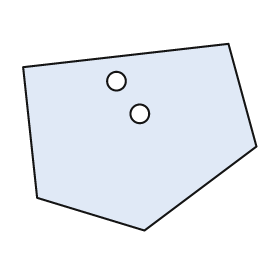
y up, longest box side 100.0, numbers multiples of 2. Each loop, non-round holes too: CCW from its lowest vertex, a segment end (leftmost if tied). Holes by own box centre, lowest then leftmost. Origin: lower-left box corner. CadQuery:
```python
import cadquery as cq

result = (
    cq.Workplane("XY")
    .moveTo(52.0, 0.0)
    .lineTo(100.0, 36.0)
    .lineTo(88.0, 80.0)
    .lineTo(0.0, 70.0)
    .lineTo(6.0, 14.0)
    .close()
    .moveTo(50.0, 50.0)
    .circle(4.0)
    .moveTo(40.0, 64.0)
    .circle(4.0)
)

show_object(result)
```